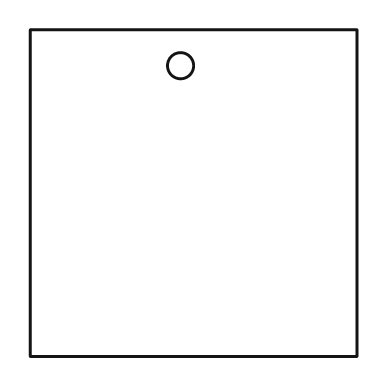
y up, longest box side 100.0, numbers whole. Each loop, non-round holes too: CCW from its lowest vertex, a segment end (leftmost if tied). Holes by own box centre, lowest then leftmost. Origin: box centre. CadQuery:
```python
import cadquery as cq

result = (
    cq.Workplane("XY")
    .moveTo(-50.0, -50.0)
    .lineTo(50.0, -50.0)
    .lineTo(50.0, 50.0)
    .lineTo(-50.0, 50.0)
    .close()
    .moveTo(-4.0, 39.0)
    .circle(4.0)
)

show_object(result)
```